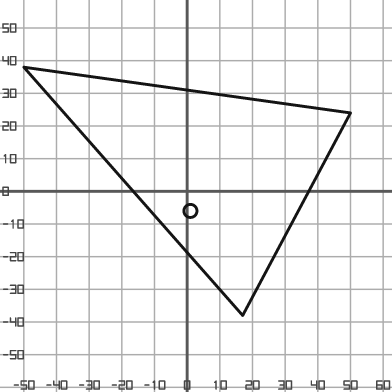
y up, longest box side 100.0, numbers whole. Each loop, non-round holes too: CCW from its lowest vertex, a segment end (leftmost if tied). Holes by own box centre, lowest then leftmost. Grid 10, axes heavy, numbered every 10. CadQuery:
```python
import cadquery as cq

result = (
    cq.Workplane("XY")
    .moveTo(17.0, -38.0)
    .lineTo(50.0, 24.0)
    .lineTo(-50.0, 38.0)
    .close()
    .moveTo(1.0, -6.0)
    .circle(2.0)
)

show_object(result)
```